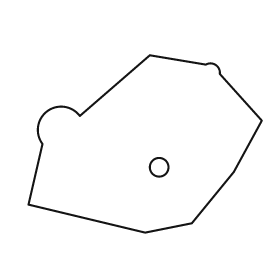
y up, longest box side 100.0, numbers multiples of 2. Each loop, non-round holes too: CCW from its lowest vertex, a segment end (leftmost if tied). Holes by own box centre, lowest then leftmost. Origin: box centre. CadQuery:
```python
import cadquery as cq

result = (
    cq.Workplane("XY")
    .moveTo(0.0, -38.0)
    .lineTo(20.0, -34.0)
    .lineTo(38.0, -12.0)
    .lineTo(50.0, 10.0)
    .lineTo(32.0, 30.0)
    .threePointArc((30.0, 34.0), (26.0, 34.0))
    .lineTo(2.0, 38.0)
    .lineTo(-28.0, 12.0)
    .threePointArc((-42.0, 14.0), (-44.0, 0.0))
    .lineTo(-50.0, -26.0)
    .close()
    .moveTo(6.0, -10.0)
    .circle(4.0)
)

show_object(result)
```